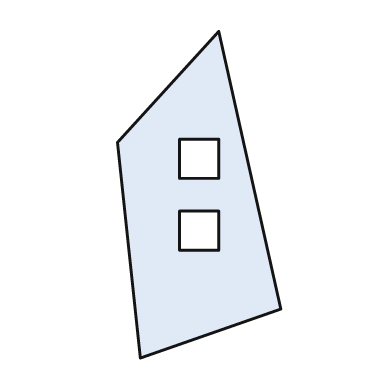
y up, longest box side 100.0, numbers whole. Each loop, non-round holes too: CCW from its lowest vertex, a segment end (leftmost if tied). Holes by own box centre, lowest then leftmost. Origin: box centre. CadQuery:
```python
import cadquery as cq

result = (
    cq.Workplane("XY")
    .moveTo(-18.0, -50.0)
    .lineTo(25.0, -35.0)
    .lineTo(6.0, 50.0)
    .lineTo(-25.0, 16.0)
    .close()
    .moveTo(-6.0, -17.0)
    .lineTo(6.0, -17.0)
    .lineTo(6.0, -5.0)
    .lineTo(-6.0, -5.0)
    .close()
    .moveTo(-6.0, 5.0)
    .lineTo(6.0, 5.0)
    .lineTo(6.0, 17.0)
    .lineTo(-6.0, 17.0)
    .close()
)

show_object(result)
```